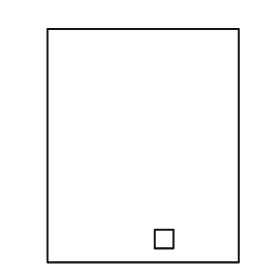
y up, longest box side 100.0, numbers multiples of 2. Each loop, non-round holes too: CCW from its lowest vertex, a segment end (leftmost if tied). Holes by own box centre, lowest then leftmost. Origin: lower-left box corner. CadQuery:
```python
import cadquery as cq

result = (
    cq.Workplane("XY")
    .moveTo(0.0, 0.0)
    .lineTo(82.0, 0.0)
    .lineTo(82.0, 100.0)
    .lineTo(0.0, 100.0)
    .close()
    .moveTo(46.0, 6.0)
    .lineTo(54.0, 6.0)
    .lineTo(54.0, 14.0)
    .lineTo(46.0, 14.0)
    .close()
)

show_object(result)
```